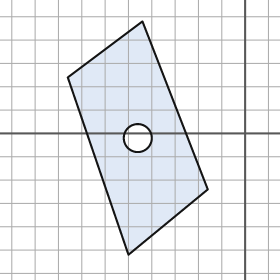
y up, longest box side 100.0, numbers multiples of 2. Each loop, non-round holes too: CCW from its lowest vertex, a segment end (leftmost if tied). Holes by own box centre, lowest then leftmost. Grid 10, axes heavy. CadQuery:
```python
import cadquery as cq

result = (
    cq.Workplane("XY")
    .moveTo(-50.0, -52.0)
    .lineTo(-16.0, -24.0)
    .lineTo(-44.0, 48.0)
    .lineTo(-76.0, 24.0)
    .close()
    .moveTo(-46.0, -2.0)
    .circle(6.0)
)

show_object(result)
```